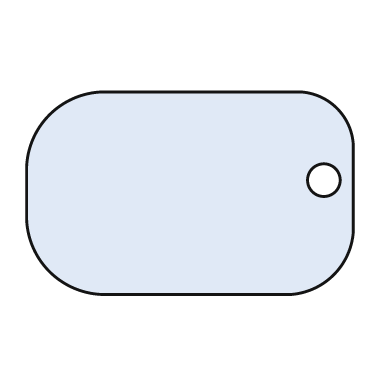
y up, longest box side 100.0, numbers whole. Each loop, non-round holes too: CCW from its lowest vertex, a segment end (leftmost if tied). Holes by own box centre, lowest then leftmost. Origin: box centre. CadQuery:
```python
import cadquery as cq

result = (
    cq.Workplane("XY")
    .moveTo(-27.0, -31.0)
    .lineTo(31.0, -31.0)
    .threePointArc((44.0, -25.0), (50.0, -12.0))
    .lineTo(50.0, 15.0)
    .threePointArc((45.0, 26.0), (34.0, 31.0))
    .lineTo(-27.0, 31.0)
    .threePointArc((-43.0, 24.0), (-50.0, 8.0))
    .lineTo(-50.0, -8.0)
    .threePointArc((-43.0, -24.0), (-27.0, -31.0))
    .close()
    .moveTo(41.0, 4.0)
    .circle(5.0)
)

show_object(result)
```